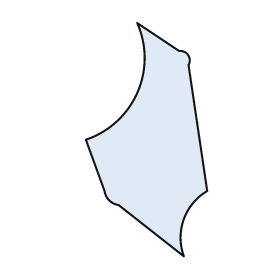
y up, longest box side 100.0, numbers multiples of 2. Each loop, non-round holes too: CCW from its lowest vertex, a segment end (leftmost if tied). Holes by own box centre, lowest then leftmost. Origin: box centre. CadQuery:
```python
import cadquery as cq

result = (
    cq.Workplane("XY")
    .moveTo(16.0, -50.0)
    .threePointArc((16.0, -34.0), (26.0, -22.0))
    .lineTo(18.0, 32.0)
    .threePointArc((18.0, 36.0), (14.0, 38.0))
    .lineTo(-4.0, 50.0)
    .threePointArc((-4.0, 20.0), (-26.0, 0.0))
    .lineTo(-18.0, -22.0)
    .threePointArc((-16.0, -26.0), (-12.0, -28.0))
    .close()
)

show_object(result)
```